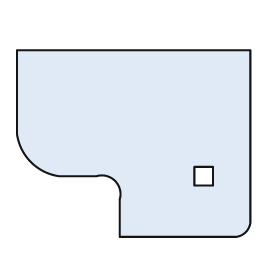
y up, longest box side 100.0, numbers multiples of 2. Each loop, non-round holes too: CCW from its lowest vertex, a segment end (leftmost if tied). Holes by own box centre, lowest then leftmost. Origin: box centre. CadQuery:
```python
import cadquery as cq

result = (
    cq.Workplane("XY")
    .moveTo(-6.0, -40.0)
    .lineTo(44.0, -40.0)
    .threePointArc((48.0, -38.0), (50.0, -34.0))
    .lineTo(50.0, 40.0)
    .lineTo(-50.0, 40.0)
    .lineTo(-50.0, 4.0)
    .threePointArc((-44.0, -8.0), (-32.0, -14.0))
    .lineTo(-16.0, -14.0)
    .threePointArc((-8.0, -16.0), (-6.0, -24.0))
    .close()
    .moveTo(26.0, -18.0)
    .lineTo(34.0, -18.0)
    .lineTo(34.0, -10.0)
    .lineTo(26.0, -10.0)
    .close()
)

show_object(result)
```